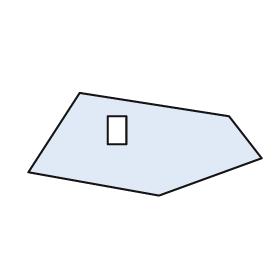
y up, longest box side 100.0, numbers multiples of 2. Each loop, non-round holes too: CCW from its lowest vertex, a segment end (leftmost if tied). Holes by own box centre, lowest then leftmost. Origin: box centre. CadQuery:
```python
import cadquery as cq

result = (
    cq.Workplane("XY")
    .moveTo(6.0, -22.0)
    .lineTo(50.0, -6.0)
    .lineTo(36.0, 12.0)
    .lineTo(-28.0, 22.0)
    .lineTo(-50.0, -12.0)
    .close()
    .moveTo(-16.0, 0.0)
    .lineTo(-8.0, 0.0)
    .lineTo(-8.0, 12.0)
    .lineTo(-16.0, 12.0)
    .close()
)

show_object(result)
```